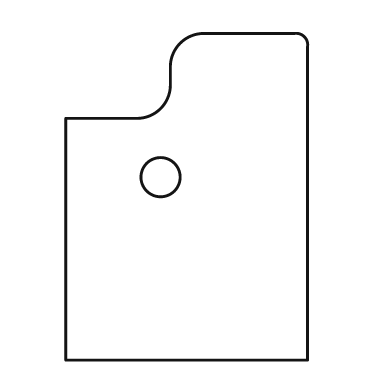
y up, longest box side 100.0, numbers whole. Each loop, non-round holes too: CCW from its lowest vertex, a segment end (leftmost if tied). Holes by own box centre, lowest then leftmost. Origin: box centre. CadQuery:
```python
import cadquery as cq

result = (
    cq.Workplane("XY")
    .moveTo(-37.0, -50.0)
    .lineTo(37.0, -50.0)
    .lineTo(37.0, 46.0)
    .threePointArc((36.0, 49.0), (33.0, 50.0))
    .lineTo(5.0, 50.0)
    .threePointArc((-2.0, 47.0), (-5.0, 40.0))
    .lineTo(-5.0, 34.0)
    .threePointArc((-8.0, 27.0), (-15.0, 24.0))
    .lineTo(-37.0, 24.0)
    .close()
    .moveTo(-8.0, 6.0)
    .circle(6.0)
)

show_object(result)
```